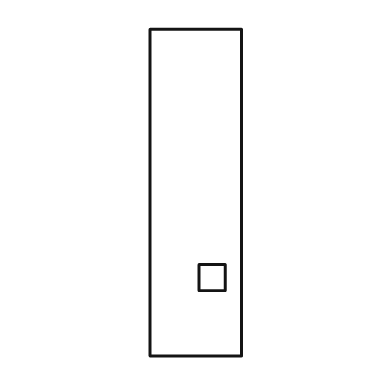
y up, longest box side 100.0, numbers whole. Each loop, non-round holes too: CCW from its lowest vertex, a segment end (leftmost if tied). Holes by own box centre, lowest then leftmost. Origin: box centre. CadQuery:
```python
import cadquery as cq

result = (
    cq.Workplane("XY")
    .moveTo(-14.0, -50.0)
    .lineTo(14.0, -50.0)
    .lineTo(14.0, 50.0)
    .lineTo(-14.0, 50.0)
    .close()
    .moveTo(1.0, -30.0)
    .lineTo(9.0, -30.0)
    .lineTo(9.0, -22.0)
    .lineTo(1.0, -22.0)
    .close()
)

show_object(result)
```